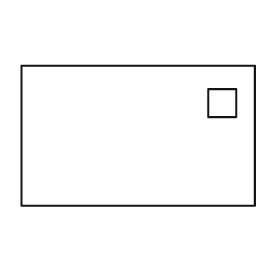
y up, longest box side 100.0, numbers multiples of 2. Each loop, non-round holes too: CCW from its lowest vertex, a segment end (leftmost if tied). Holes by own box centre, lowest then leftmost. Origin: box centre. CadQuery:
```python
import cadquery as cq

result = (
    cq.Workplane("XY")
    .moveTo(-50.0, -30.0)
    .lineTo(50.0, -30.0)
    .lineTo(50.0, 30.0)
    .lineTo(-50.0, 30.0)
    .close()
    .moveTo(30.0, 8.0)
    .lineTo(42.0, 8.0)
    .lineTo(42.0, 20.0)
    .lineTo(30.0, 20.0)
    .close()
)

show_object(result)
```